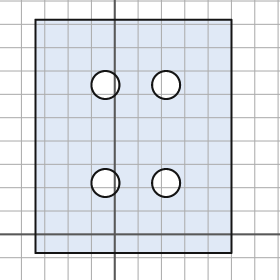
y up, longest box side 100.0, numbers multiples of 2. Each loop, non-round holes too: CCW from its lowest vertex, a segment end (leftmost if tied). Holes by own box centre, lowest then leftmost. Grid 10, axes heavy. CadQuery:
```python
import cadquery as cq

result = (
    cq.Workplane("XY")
    .moveTo(-34.0, -8.0)
    .lineTo(50.0, -8.0)
    .lineTo(50.0, 92.0)
    .lineTo(-34.0, 92.0)
    .close()
    .moveTo(-4.0, 22.0)
    .circle(6.0)
    .moveTo(22.0, 22.0)
    .circle(6.0)
    .moveTo(-4.0, 64.0)
    .circle(6.0)
    .moveTo(22.0, 64.0)
    .circle(6.0)
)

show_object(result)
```